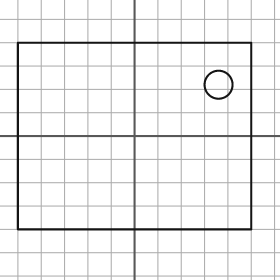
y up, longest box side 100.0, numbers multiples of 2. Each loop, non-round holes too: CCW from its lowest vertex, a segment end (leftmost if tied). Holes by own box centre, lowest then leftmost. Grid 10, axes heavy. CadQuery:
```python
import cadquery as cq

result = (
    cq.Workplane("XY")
    .moveTo(-50.0, -40.0)
    .lineTo(50.0, -40.0)
    .lineTo(50.0, 40.0)
    .lineTo(-50.0, 40.0)
    .close()
    .moveTo(36.0, 22.0)
    .circle(6.0)
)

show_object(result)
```